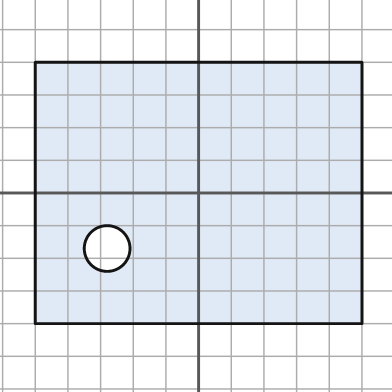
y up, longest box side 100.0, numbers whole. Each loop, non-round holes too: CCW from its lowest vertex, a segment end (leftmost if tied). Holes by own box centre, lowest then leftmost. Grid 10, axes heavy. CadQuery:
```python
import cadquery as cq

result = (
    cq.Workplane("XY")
    .moveTo(-50.0, -40.0)
    .lineTo(50.0, -40.0)
    .lineTo(50.0, 40.0)
    .lineTo(-50.0, 40.0)
    .close()
    .moveTo(-28.0, -17.0)
    .circle(7.0)
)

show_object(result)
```